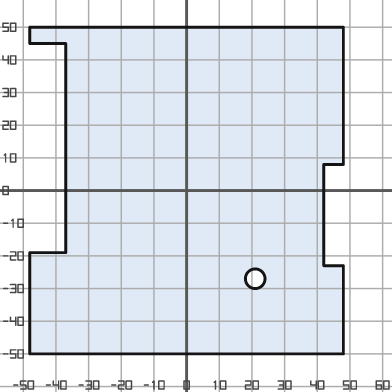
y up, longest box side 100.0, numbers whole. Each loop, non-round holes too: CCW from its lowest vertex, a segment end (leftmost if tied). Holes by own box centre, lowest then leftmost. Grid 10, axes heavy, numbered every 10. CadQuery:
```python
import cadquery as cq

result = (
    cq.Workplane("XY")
    .moveTo(-48.0, -50.0)
    .lineTo(48.0, -50.0)
    .lineTo(48.0, -23.0)
    .lineTo(42.0, -23.0)
    .lineTo(42.0, 8.0)
    .lineTo(48.0, 8.0)
    .lineTo(48.0, 50.0)
    .lineTo(-48.0, 50.0)
    .lineTo(-48.0, 45.0)
    .lineTo(-37.0, 45.0)
    .lineTo(-37.0, -19.0)
    .lineTo(-48.0, -19.0)
    .close()
    .moveTo(21.0, -27.0)
    .circle(3.0)
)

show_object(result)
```